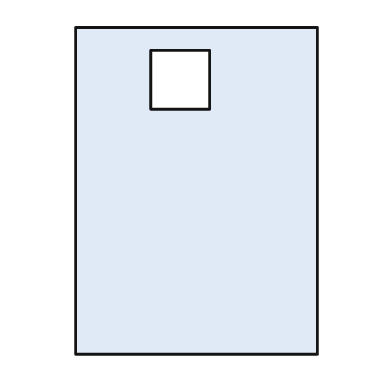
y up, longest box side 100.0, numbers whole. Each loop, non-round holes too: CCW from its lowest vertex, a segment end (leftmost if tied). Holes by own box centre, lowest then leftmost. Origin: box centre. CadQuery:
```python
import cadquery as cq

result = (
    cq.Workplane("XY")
    .moveTo(-37.0, -50.0)
    .lineTo(37.0, -50.0)
    .lineTo(37.0, 50.0)
    .lineTo(-37.0, 50.0)
    .close()
    .moveTo(-14.0, 25.0)
    .lineTo(4.0, 25.0)
    .lineTo(4.0, 43.0)
    .lineTo(-14.0, 43.0)
    .close()
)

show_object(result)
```